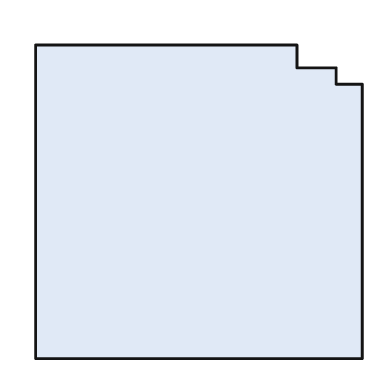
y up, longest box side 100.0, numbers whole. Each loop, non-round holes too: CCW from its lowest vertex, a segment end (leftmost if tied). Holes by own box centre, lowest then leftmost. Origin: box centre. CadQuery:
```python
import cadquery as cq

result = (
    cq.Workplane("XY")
    .moveTo(-50.0, -48.0)
    .lineTo(50.0, -48.0)
    .lineTo(50.0, 36.0)
    .lineTo(42.0, 36.0)
    .lineTo(42.0, 41.0)
    .lineTo(30.0, 41.0)
    .lineTo(30.0, 48.0)
    .lineTo(-50.0, 48.0)
    .close()
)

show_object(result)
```